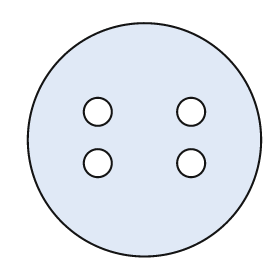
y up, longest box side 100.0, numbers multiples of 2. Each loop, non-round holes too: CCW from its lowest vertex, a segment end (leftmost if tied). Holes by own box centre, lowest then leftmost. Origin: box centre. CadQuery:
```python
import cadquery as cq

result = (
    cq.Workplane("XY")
    .moveTo(0.0, 0.0)
    .circle(50.0)
    .moveTo(-20.0, -10.0)
    .circle(6.0)
    .moveTo(20.0, -10.0)
    .circle(6.0)
    .moveTo(-20.0, 12.0)
    .circle(6.0)
    .moveTo(20.0, 12.0)
    .circle(6.0)
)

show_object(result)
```